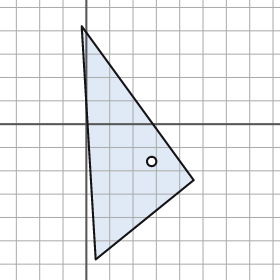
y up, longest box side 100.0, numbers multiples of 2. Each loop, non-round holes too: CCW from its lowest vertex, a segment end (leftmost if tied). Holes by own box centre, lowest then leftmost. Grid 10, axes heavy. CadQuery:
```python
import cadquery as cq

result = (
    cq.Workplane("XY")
    .moveTo(4.0, -58.0)
    .lineTo(46.0, -24.0)
    .lineTo(-2.0, 42.0)
    .close()
    .moveTo(28.0, -16.0)
    .circle(2.0)
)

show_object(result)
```